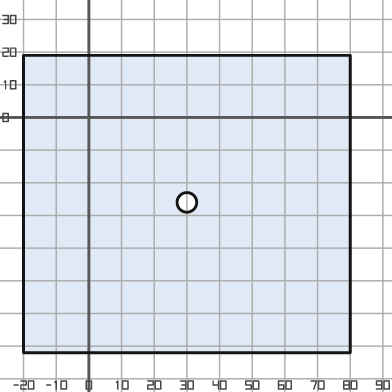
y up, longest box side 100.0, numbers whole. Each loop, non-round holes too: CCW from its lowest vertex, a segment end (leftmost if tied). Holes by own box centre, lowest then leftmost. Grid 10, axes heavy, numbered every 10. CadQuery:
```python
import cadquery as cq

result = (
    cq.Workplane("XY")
    .moveTo(-20.0, -72.0)
    .lineTo(80.0, -72.0)
    .lineTo(80.0, 19.0)
    .lineTo(-20.0, 19.0)
    .close()
    .moveTo(30.0, -26.0)
    .circle(3.0)
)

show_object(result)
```